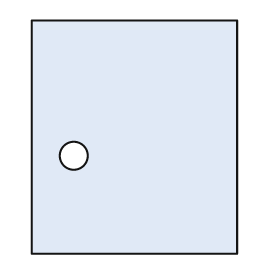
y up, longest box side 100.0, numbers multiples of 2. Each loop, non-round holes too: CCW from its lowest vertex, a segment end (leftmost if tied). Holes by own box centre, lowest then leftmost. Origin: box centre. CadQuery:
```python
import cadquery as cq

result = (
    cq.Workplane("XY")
    .moveTo(-44.0, -50.0)
    .lineTo(44.0, -50.0)
    .lineTo(44.0, 50.0)
    .lineTo(-44.0, 50.0)
    .close()
    .moveTo(-26.0, -8.0)
    .circle(6.0)
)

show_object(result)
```